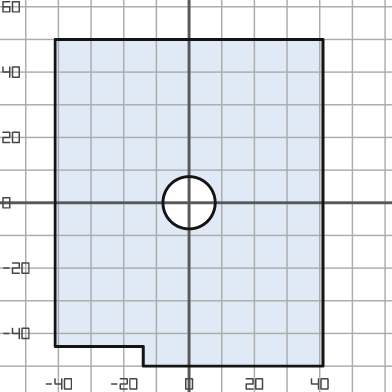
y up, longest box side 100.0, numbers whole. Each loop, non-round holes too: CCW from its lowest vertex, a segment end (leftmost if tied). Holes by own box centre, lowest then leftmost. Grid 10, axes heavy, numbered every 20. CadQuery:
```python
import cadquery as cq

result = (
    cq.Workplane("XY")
    .moveTo(-14.0, -50.0)
    .lineTo(41.0, -50.0)
    .lineTo(41.0, 50.0)
    .lineTo(-41.0, 50.0)
    .lineTo(-41.0, -44.0)
    .lineTo(-14.0, -44.0)
    .close()
    .moveTo(0.0, 0.0)
    .circle(8.0)
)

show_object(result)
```